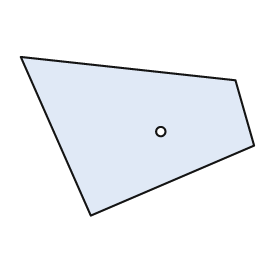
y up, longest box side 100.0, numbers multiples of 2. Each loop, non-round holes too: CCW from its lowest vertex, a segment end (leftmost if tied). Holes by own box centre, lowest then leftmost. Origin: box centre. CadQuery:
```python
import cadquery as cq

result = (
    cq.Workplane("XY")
    .moveTo(-20.0, -34.0)
    .lineTo(50.0, -4.0)
    .lineTo(42.0, 24.0)
    .lineTo(-50.0, 34.0)
    .close()
    .moveTo(10.0, 2.0)
    .circle(2.0)
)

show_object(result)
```